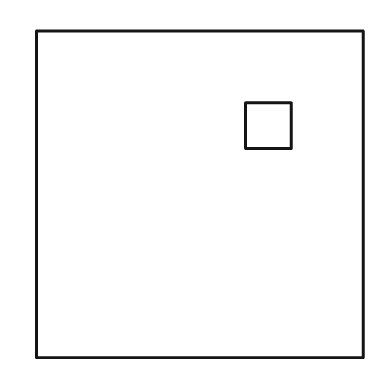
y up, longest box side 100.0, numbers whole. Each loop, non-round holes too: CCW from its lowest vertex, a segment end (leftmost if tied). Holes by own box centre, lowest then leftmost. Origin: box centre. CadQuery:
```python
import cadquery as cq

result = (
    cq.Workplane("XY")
    .moveTo(-50.0, -50.0)
    .lineTo(50.0, -50.0)
    .lineTo(50.0, 50.0)
    .lineTo(-50.0, 50.0)
    .close()
    .moveTo(14.0, 14.0)
    .lineTo(28.0, 14.0)
    .lineTo(28.0, 28.0)
    .lineTo(14.0, 28.0)
    .close()
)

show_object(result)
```